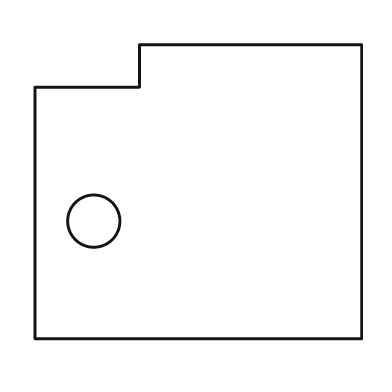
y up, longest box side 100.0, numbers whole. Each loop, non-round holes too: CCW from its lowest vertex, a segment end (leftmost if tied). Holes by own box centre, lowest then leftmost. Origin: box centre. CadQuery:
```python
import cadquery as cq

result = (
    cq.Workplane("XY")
    .moveTo(-50.0, -45.0)
    .lineTo(50.0, -45.0)
    .lineTo(50.0, 45.0)
    .lineTo(-18.0, 45.0)
    .lineTo(-18.0, 32.0)
    .lineTo(-50.0, 32.0)
    .close()
    .moveTo(-32.0, -9.0)
    .circle(8.0)
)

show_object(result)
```